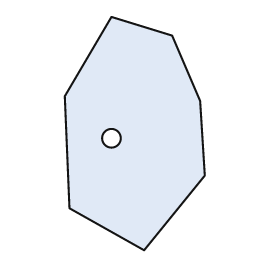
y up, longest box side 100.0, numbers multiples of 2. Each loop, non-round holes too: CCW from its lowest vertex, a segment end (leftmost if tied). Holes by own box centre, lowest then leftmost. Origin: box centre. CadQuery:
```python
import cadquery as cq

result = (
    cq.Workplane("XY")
    .moveTo(4.0, -50.0)
    .lineTo(30.0, -18.0)
    .lineTo(28.0, 14.0)
    .lineTo(16.0, 42.0)
    .lineTo(-10.0, 50.0)
    .lineTo(-30.0, 16.0)
    .lineTo(-28.0, -32.0)
    .close()
    .moveTo(-10.0, -2.0)
    .circle(4.0)
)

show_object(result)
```